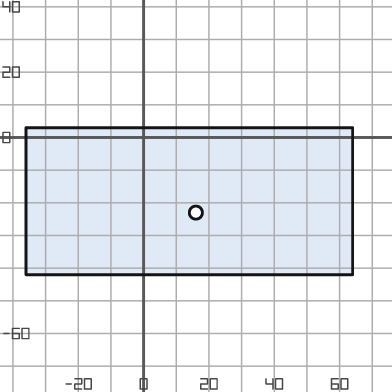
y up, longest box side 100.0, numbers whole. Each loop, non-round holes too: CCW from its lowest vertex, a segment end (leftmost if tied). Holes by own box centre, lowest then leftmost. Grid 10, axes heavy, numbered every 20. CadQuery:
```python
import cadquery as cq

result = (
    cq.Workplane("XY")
    .moveTo(-36.0, -42.0)
    .lineTo(64.0, -42.0)
    .lineTo(64.0, 3.0)
    .lineTo(-36.0, 3.0)
    .close()
    .moveTo(16.0, -23.0)
    .circle(2.0)
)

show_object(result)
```